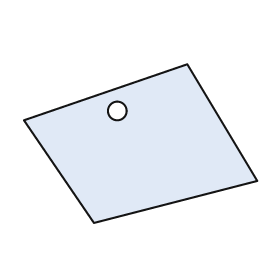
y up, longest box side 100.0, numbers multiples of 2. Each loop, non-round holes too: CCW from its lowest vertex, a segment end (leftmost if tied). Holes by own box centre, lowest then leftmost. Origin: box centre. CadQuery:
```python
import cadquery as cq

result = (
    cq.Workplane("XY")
    .moveTo(-20.0, -34.0)
    .lineTo(50.0, -16.0)
    .lineTo(20.0, 34.0)
    .lineTo(-50.0, 10.0)
    .close()
    .moveTo(-10.0, 14.0)
    .circle(4.0)
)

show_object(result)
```